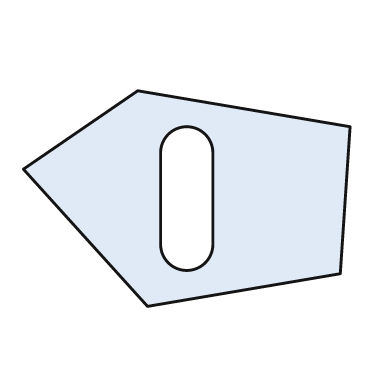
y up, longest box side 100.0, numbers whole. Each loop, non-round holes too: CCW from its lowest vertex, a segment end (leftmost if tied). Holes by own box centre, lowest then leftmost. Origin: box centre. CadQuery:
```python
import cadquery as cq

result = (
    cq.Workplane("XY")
    .moveTo(-12.0, -33.0)
    .lineTo(47.0, -23.0)
    .lineTo(50.0, 22.0)
    .lineTo(-15.0, 33.0)
    .lineTo(-50.0, 9.0)
    .close()
    .moveTo(-8.0, -14.0)
    .threePointArc((0.0, -22.0), (8.0, -14.0))
    .lineTo(8.0, 14.0)
    .threePointArc((0.0, 22.0), (-8.0, 14.0))
    .close()
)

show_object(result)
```